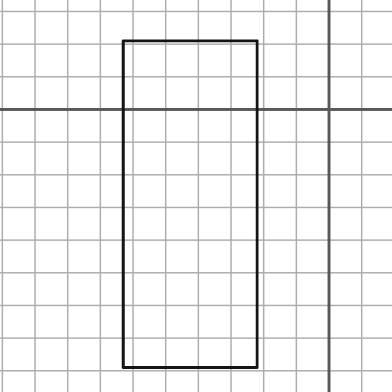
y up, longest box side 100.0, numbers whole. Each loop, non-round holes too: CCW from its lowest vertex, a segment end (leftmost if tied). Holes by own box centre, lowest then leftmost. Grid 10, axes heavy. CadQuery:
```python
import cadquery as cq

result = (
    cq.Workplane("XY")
    .moveTo(-63.0, -79.0)
    .lineTo(-22.0, -79.0)
    .lineTo(-22.0, 21.0)
    .lineTo(-63.0, 21.0)
    .close()
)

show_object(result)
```